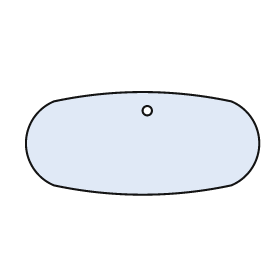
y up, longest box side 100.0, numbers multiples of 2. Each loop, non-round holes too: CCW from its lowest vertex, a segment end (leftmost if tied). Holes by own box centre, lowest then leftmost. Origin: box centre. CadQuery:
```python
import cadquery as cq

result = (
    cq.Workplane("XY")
    .moveTo(-38.0, -18.0)
    .threePointArc((0.0, -22.0), (38.0, -18.0))
    .threePointArc((50.0, 0.0), (38.0, 18.0))
    .threePointArc((0.0, 22.0), (-38.0, 18.0))
    .threePointArc((-50.0, 0.0), (-38.0, -18.0))
    .close()
    .moveTo(2.0, 14.0)
    .circle(2.0)
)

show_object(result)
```